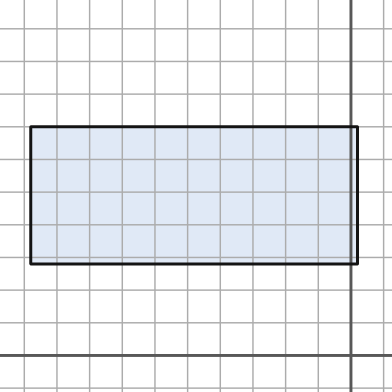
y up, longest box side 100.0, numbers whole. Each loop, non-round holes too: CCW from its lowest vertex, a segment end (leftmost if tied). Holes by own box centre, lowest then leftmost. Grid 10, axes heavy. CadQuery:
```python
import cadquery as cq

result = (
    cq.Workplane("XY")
    .moveTo(-98.0, 28.0)
    .lineTo(2.0, 28.0)
    .lineTo(2.0, 70.0)
    .lineTo(-98.0, 70.0)
    .close()
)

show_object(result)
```